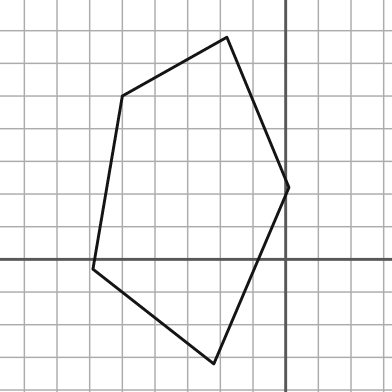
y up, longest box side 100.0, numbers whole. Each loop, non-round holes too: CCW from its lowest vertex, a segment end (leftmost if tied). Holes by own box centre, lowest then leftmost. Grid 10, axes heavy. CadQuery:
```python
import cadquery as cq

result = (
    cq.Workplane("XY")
    .moveTo(-22.0, -32.0)
    .lineTo(1.0, 22.0)
    .lineTo(-18.0, 68.0)
    .lineTo(-50.0, 50.0)
    .lineTo(-59.0, -3.0)
    .close()
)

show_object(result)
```